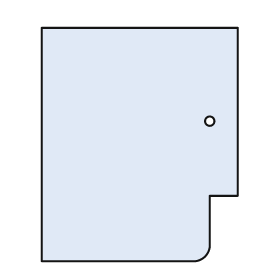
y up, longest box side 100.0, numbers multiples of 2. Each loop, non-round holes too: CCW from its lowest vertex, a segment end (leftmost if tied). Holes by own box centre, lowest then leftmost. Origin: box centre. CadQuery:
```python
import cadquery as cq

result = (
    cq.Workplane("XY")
    .moveTo(-42.0, -50.0)
    .lineTo(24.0, -50.0)
    .threePointArc((28.0, -48.0), (30.0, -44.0))
    .lineTo(30.0, -22.0)
    .lineTo(42.0, -22.0)
    .lineTo(42.0, 50.0)
    .lineTo(-42.0, 50.0)
    .close()
    .moveTo(30.0, 10.0)
    .circle(2.0)
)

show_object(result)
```